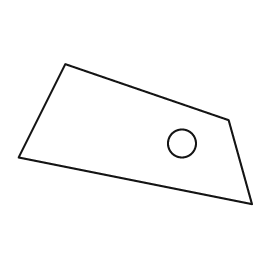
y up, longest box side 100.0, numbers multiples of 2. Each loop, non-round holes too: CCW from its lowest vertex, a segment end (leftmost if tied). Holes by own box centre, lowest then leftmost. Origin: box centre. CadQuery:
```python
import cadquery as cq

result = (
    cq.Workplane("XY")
    .moveTo(50.0, -30.0)
    .lineTo(40.0, 6.0)
    .lineTo(-30.0, 30.0)
    .lineTo(-50.0, -10.0)
    .close()
    .moveTo(20.0, -4.0)
    .circle(6.0)
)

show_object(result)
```